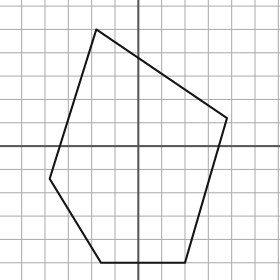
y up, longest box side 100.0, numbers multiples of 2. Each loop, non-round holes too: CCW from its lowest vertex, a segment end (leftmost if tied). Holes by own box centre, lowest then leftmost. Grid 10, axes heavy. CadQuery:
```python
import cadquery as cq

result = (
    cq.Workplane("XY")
    .moveTo(-16.0, -50.0)
    .lineTo(20.0, -50.0)
    .lineTo(38.0, 12.0)
    .lineTo(-18.0, 50.0)
    .lineTo(-38.0, -14.0)
    .close()
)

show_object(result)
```